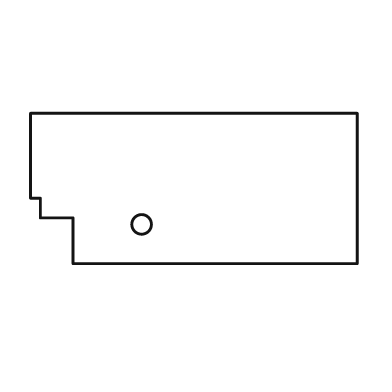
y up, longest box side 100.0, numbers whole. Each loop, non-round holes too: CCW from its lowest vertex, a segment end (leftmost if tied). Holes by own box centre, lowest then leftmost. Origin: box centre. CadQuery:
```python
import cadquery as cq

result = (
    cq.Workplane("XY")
    .moveTo(-37.0, -23.0)
    .lineTo(50.0, -23.0)
    .lineTo(50.0, 23.0)
    .lineTo(-50.0, 23.0)
    .lineTo(-50.0, -3.0)
    .lineTo(-47.0, -3.0)
    .lineTo(-47.0, -9.0)
    .lineTo(-37.0, -9.0)
    .close()
    .moveTo(-16.0, -11.0)
    .circle(3.0)
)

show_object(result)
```